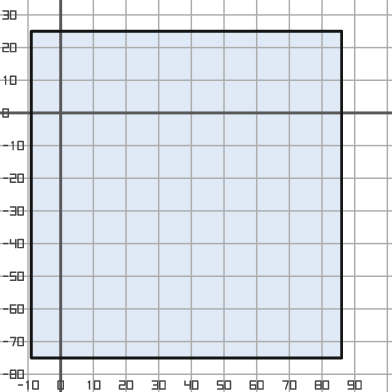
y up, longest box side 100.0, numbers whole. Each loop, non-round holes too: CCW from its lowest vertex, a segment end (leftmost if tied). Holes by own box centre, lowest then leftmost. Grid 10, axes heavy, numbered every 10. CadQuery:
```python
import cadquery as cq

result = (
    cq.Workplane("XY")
    .moveTo(-9.0, -75.0)
    .lineTo(86.0, -75.0)
    .lineTo(86.0, 25.0)
    .lineTo(-9.0, 25.0)
    .close()
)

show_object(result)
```